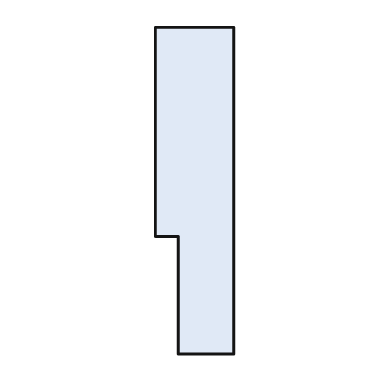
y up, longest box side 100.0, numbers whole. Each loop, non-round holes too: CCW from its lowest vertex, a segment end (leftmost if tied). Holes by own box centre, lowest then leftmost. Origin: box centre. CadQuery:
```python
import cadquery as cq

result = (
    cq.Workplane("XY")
    .moveTo(-5.0, -50.0)
    .lineTo(12.0, -50.0)
    .lineTo(12.0, 50.0)
    .lineTo(-12.0, 50.0)
    .lineTo(-12.0, -14.0)
    .lineTo(-5.0, -14.0)
    .close()
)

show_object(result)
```